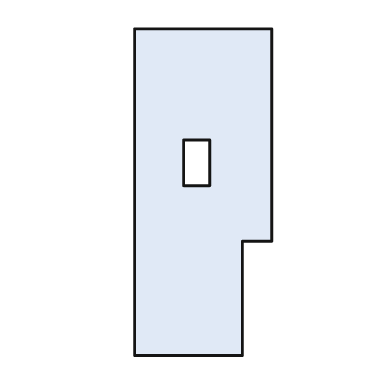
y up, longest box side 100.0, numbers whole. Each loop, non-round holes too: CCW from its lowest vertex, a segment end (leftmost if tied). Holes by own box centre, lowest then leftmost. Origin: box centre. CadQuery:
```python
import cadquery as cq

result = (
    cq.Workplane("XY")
    .moveTo(-21.0, -50.0)
    .lineTo(12.0, -50.0)
    .lineTo(12.0, -15.0)
    .lineTo(21.0, -15.0)
    .lineTo(21.0, 50.0)
    .lineTo(-21.0, 50.0)
    .close()
    .moveTo(-6.0, 2.0)
    .lineTo(2.0, 2.0)
    .lineTo(2.0, 16.0)
    .lineTo(-6.0, 16.0)
    .close()
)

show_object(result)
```